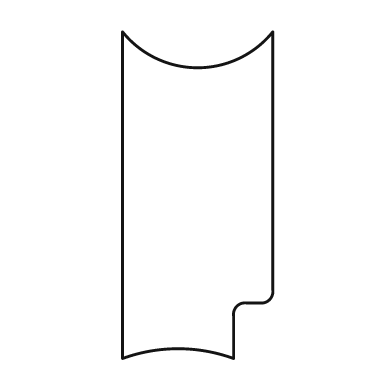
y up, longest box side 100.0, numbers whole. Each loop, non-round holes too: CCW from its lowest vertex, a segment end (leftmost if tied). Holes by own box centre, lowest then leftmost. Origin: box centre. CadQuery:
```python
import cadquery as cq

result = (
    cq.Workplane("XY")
    .moveTo(-23.0, -50.0)
    .threePointArc((-6.0, -47.0), (11.0, -50.0))
    .lineTo(11.0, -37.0)
    .threePointArc((12.0, -34.0), (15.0, -33.0))
    .lineTo(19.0, -33.0)
    .threePointArc((22.0, -32.0), (23.0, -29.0))
    .lineTo(23.0, 50.0)
    .threePointArc((0.0, 39.0), (-23.0, 50.0))
    .close()
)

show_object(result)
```